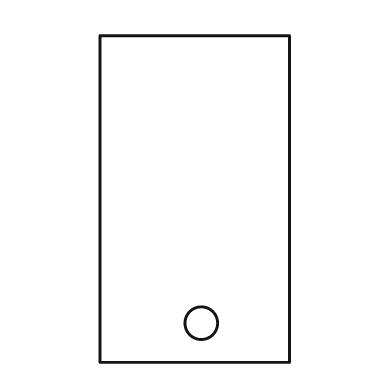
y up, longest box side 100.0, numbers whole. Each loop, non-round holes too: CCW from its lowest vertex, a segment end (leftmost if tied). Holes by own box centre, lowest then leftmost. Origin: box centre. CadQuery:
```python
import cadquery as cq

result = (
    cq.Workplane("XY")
    .moveTo(-29.0, -50.0)
    .lineTo(29.0, -50.0)
    .lineTo(29.0, 50.0)
    .lineTo(-29.0, 50.0)
    .close()
    .moveTo(2.0, -38.0)
    .circle(5.0)
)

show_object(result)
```